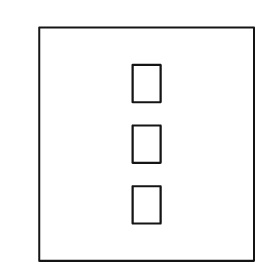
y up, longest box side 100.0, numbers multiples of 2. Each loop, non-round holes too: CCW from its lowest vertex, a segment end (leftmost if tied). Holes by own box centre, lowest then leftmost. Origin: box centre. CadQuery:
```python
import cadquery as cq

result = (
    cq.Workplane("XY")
    .moveTo(-46.0, -50.0)
    .lineTo(46.0, -50.0)
    .lineTo(46.0, 50.0)
    .lineTo(-46.0, 50.0)
    .close()
    .moveTo(-6.0, -34.0)
    .lineTo(6.0, -34.0)
    .lineTo(6.0, -18.0)
    .lineTo(-6.0, -18.0)
    .close()
    .moveTo(-6.0, -8.0)
    .lineTo(6.0, -8.0)
    .lineTo(6.0, 8.0)
    .lineTo(-6.0, 8.0)
    .close()
    .moveTo(-6.0, 18.0)
    .lineTo(6.0, 18.0)
    .lineTo(6.0, 34.0)
    .lineTo(-6.0, 34.0)
    .close()
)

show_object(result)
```